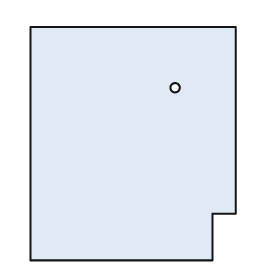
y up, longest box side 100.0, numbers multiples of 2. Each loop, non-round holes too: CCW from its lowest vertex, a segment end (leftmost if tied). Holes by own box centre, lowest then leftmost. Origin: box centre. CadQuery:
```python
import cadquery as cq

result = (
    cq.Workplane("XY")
    .moveTo(-44.0, -50.0)
    .lineTo(34.0, -50.0)
    .lineTo(34.0, -30.0)
    .lineTo(44.0, -30.0)
    .lineTo(44.0, 50.0)
    .lineTo(-44.0, 50.0)
    .close()
    .moveTo(18.0, 24.0)
    .circle(2.0)
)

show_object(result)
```